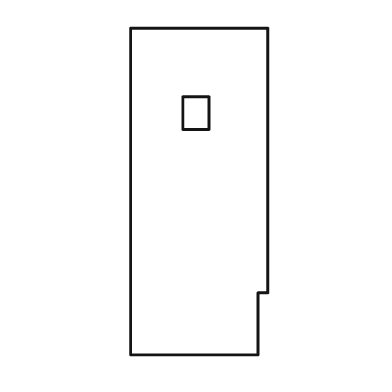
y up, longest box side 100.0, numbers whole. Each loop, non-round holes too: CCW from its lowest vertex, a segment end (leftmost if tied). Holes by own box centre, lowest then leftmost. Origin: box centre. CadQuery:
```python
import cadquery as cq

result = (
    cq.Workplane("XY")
    .moveTo(-21.0, -50.0)
    .lineTo(18.0, -50.0)
    .lineTo(18.0, -31.0)
    .lineTo(21.0, -31.0)
    .lineTo(21.0, 50.0)
    .lineTo(-21.0, 50.0)
    .close()
    .moveTo(-5.0, 19.0)
    .lineTo(3.0, 19.0)
    .lineTo(3.0, 29.0)
    .lineTo(-5.0, 29.0)
    .close()
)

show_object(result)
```